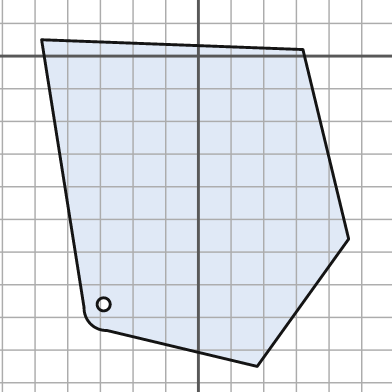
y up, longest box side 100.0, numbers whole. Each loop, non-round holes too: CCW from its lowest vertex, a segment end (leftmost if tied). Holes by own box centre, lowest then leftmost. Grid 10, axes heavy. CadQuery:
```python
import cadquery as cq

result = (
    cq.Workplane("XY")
    .moveTo(18.0, -95.0)
    .lineTo(46.0, -56.0)
    .lineTo(32.0, 2.0)
    .lineTo(-48.0, 5.0)
    .lineTo(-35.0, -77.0)
    .threePointArc((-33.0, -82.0), (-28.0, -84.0))
    .close()
    .moveTo(-29.0, -76.0)
    .circle(2.0)
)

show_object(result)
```